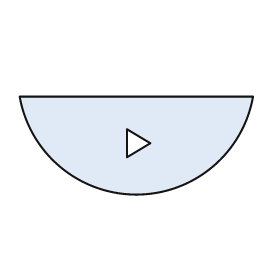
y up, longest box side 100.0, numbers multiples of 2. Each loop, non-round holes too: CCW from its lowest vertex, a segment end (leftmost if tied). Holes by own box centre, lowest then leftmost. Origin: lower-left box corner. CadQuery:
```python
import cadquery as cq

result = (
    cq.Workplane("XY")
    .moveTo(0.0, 42.0)
    .threePointArc((50.0, 0.0), (100.0, 42.0))
    .close()
    .moveTo(46.0, 16.0)
    .lineTo(56.0, 22.0)
    .lineTo(46.0, 28.0)
    .close()
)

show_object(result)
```